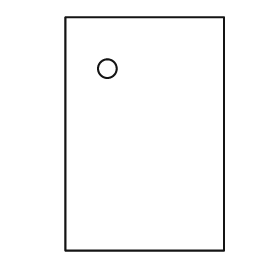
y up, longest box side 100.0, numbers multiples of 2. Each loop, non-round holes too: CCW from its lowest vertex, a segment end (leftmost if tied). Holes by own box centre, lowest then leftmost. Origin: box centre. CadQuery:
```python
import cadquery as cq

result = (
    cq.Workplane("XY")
    .moveTo(-34.0, -50.0)
    .lineTo(34.0, -50.0)
    .lineTo(34.0, 50.0)
    .lineTo(-34.0, 50.0)
    .close()
    .moveTo(-16.0, 28.0)
    .circle(4.0)
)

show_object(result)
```